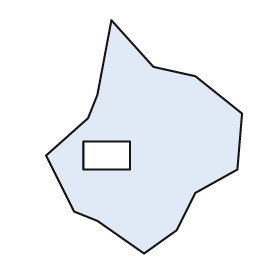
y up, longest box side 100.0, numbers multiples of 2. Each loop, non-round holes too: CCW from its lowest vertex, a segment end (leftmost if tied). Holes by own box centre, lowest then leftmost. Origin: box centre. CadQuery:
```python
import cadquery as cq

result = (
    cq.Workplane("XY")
    .moveTo(0.0, -50.0)
    .lineTo(14.0, -40.0)
    .lineTo(22.0, -24.0)
    .lineTo(40.0, -14.0)
    .lineTo(42.0, 10.0)
    .lineTo(22.0, 26.0)
    .lineTo(4.0, 30.0)
    .lineTo(-14.0, 50.0)
    .lineTo(-20.0, 18.0)
    .lineTo(-24.0, 8.0)
    .lineTo(-42.0, -8.0)
    .lineTo(-30.0, -32.0)
    .lineTo(-20.0, -36.0)
    .close()
    .moveTo(-26.0, -14.0)
    .lineTo(-6.0, -14.0)
    .lineTo(-6.0, -2.0)
    .lineTo(-26.0, -2.0)
    .close()
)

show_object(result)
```